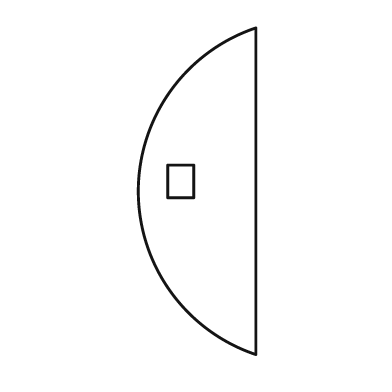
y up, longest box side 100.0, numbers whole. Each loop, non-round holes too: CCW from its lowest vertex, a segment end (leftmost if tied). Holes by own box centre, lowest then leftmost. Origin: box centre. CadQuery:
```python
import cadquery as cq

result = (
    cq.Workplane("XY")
    .moveTo(18.0, -50.0)
    .lineTo(18.0, 50.0)
    .threePointArc((-18.0, 0.0), (18.0, -50.0))
    .close()
    .moveTo(-9.0, -2.0)
    .lineTo(-1.0, -2.0)
    .lineTo(-1.0, 8.0)
    .lineTo(-9.0, 8.0)
    .close()
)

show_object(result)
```